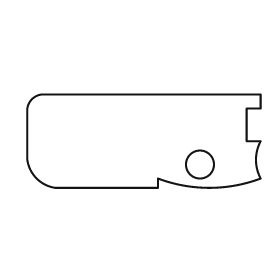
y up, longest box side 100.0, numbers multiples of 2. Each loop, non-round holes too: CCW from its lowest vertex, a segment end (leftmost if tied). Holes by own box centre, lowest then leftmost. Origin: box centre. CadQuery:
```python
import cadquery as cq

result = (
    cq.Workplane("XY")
    .moveTo(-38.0, -20.0)
    .lineTo(6.0, -20.0)
    .lineTo(6.0, -16.0)
    .threePointArc((28.0, -20.0), (50.0, -16.0))
    .threePointArc((48.0, -8.0), (50.0, 0.0))
    .lineTo(44.0, 0.0)
    .lineTo(44.0, 14.0)
    .lineTo(50.0, 14.0)
    .lineTo(50.0, 20.0)
    .lineTo(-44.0, 20.0)
    .threePointArc((-48.0, 18.0), (-50.0, 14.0))
    .lineTo(-50.0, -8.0)
    .threePointArc((-46.0, -16.0), (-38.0, -20.0))
    .close()
    .moveTo(24.0, -10.0)
    .circle(6.0)
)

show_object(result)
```